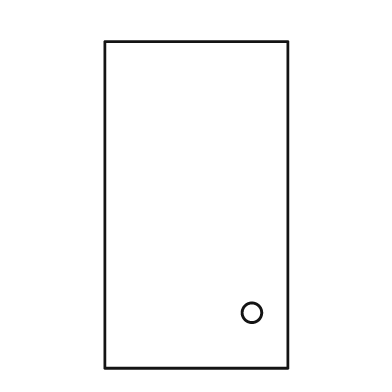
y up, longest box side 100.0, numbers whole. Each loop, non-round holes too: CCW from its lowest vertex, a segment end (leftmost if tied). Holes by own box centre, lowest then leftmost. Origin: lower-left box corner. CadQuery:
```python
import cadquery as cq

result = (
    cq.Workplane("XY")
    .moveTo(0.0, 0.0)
    .lineTo(56.0, 0.0)
    .lineTo(56.0, 100.0)
    .lineTo(0.0, 100.0)
    .close()
    .moveTo(45.0, 17.0)
    .circle(3.0)
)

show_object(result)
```